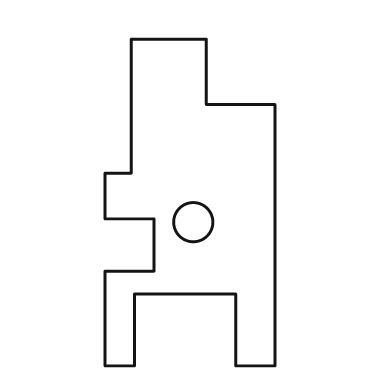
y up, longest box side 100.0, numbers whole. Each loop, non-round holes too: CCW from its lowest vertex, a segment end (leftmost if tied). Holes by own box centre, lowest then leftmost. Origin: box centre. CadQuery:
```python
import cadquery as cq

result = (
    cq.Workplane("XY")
    .moveTo(-26.0, -50.0)
    .lineTo(-17.0, -50.0)
    .lineTo(-17.0, -28.0)
    .lineTo(14.0, -28.0)
    .lineTo(14.0, -50.0)
    .lineTo(26.0, -50.0)
    .lineTo(26.0, 30.0)
    .lineTo(5.0, 30.0)
    .lineTo(5.0, 50.0)
    .lineTo(-18.0, 50.0)
    .lineTo(-18.0, 9.0)
    .lineTo(-26.0, 9.0)
    .lineTo(-26.0, -5.0)
    .lineTo(-11.0, -5.0)
    .lineTo(-11.0, -21.0)
    .lineTo(-26.0, -21.0)
    .close()
    .moveTo(1.0, -6.0)
    .circle(6.0)
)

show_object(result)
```